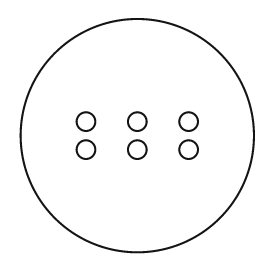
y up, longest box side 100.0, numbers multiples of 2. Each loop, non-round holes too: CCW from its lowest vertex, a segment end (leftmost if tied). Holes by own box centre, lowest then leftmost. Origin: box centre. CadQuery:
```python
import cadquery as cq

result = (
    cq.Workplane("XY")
    .moveTo(0.0, 0.0)
    .circle(50.0)
    .moveTo(-22.0, -6.0)
    .circle(4.0)
    .moveTo(0.0, -6.0)
    .circle(4.0)
    .moveTo(22.0, -6.0)
    .circle(4.0)
    .moveTo(-22.0, 6.0)
    .circle(4.0)
    .moveTo(0.0, 6.0)
    .circle(4.0)
    .moveTo(22.0, 6.0)
    .circle(4.0)
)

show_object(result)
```